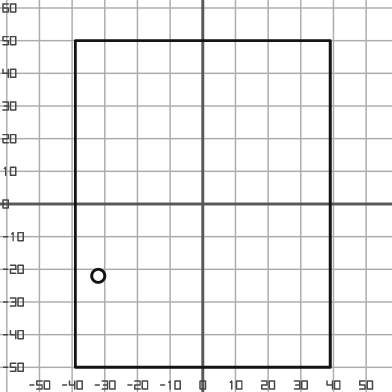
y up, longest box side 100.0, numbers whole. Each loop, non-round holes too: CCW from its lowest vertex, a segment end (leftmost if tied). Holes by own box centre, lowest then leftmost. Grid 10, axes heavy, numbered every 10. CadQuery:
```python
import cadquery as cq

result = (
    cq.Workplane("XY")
    .moveTo(-39.0, -50.0)
    .lineTo(39.0, -50.0)
    .lineTo(39.0, 50.0)
    .lineTo(-39.0, 50.0)
    .close()
    .moveTo(-32.0, -22.0)
    .circle(2.0)
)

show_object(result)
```